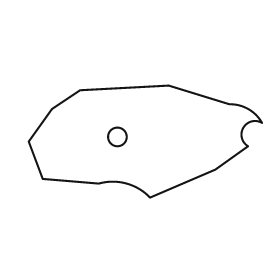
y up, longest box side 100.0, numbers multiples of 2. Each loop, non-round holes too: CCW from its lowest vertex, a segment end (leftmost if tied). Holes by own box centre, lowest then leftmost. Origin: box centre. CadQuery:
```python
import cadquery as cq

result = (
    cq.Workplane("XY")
    .moveTo(2.0, -24.0)
    .lineTo(30.0, -12.0)
    .lineTo(44.0, -2.0)
    .threePointArc((42.0, 6.0), (50.0, 8.0))
    .threePointArc((44.0, 14.0), (36.0, 16.0))
    .lineTo(10.0, 24.0)
    .lineTo(-28.0, 22.0)
    .lineTo(-40.0, 14.0)
    .lineTo(-50.0, 0.0)
    .lineTo(-44.0, -16.0)
    .lineTo(-20.0, -18.0)
    .threePointArc((-8.0, -18.0), (2.0, -24.0))
    .close()
    .moveTo(-12.0, 2.0)
    .circle(4.0)
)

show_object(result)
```